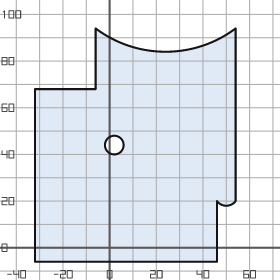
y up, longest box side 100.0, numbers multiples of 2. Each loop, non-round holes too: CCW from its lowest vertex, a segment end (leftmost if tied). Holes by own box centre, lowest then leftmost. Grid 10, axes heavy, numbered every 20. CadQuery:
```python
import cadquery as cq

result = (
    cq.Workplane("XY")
    .moveTo(-32.0, -6.0)
    .lineTo(46.0, -6.0)
    .lineTo(46.0, 20.0)
    .threePointArc((50.0, 18.0), (54.0, 20.0))
    .lineTo(54.0, 94.0)
    .threePointArc((24.0, 84.0), (-6.0, 94.0))
    .lineTo(-6.0, 68.0)
    .lineTo(-32.0, 68.0)
    .close()
    .moveTo(2.0, 44.0)
    .circle(4.0)
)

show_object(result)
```